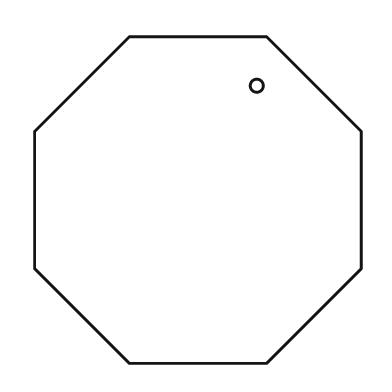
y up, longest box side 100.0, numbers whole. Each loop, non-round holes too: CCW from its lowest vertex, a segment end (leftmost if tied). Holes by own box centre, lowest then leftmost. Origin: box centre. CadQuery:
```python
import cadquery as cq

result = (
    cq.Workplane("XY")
    .moveTo(-21.0, -50.0)
    .lineTo(21.0, -50.0)
    .lineTo(50.0, -21.0)
    .lineTo(50.0, 21.0)
    .lineTo(21.0, 50.0)
    .lineTo(-21.0, 50.0)
    .lineTo(-50.0, 21.0)
    .lineTo(-50.0, -21.0)
    .close()
    .moveTo(18.0, 35.0)
    .circle(2.0)
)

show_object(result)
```